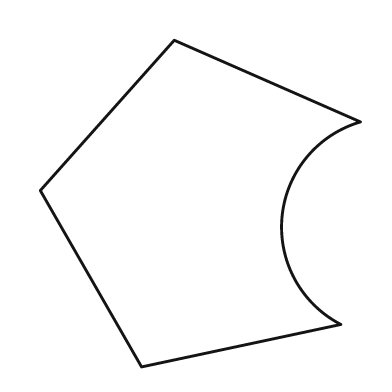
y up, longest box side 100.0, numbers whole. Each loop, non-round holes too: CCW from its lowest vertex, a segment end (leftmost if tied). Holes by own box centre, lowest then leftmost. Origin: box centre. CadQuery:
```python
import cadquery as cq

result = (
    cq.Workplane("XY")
    .moveTo(-18.0, -50.0)
    .lineTo(43.0, -37.0)
    .threePointArc((25.0, -4.0), (49.0, 25.0))
    .lineTo(-8.0, 50.0)
    .lineTo(-49.0, 4.0)
    .close()
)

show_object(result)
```